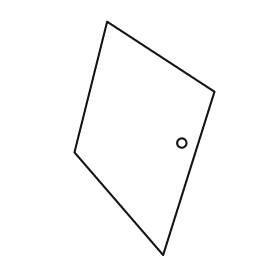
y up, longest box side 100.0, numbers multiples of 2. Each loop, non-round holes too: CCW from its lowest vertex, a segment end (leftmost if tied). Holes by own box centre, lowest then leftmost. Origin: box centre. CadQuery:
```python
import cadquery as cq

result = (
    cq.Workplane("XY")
    .moveTo(8.0, -50.0)
    .lineTo(30.0, 20.0)
    .lineTo(-16.0, 50.0)
    .lineTo(-30.0, -6.0)
    .close()
    .moveTo(16.0, -2.0)
    .circle(2.0)
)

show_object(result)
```